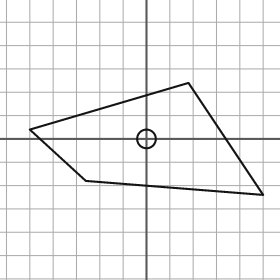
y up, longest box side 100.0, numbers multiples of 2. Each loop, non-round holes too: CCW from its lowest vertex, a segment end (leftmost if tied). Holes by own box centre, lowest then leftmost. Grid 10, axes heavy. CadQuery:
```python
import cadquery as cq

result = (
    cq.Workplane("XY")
    .moveTo(50.0, -24.0)
    .lineTo(18.0, 24.0)
    .lineTo(-50.0, 4.0)
    .lineTo(-26.0, -18.0)
    .close()
    .moveTo(0.0, 0.0)
    .circle(4.0)
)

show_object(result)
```